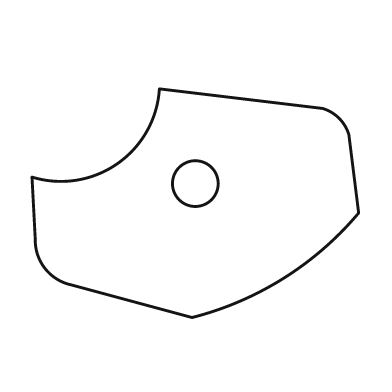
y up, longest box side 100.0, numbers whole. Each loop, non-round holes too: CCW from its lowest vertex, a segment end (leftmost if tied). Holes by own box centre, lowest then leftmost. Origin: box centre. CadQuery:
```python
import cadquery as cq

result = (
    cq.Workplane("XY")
    .moveTo(-1.0, -35.0)
    .threePointArc((27.0, -23.0), (50.0, -3.0))
    .lineTo(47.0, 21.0)
    .threePointArc((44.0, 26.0), (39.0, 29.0))
    .lineTo(-11.0, 35.0)
    .threePointArc((-24.0, 12.0), (-50.0, 8.0))
    .lineTo(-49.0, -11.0)
    .threePointArc((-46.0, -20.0), (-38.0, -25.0))
    .close()
    .moveTo(0.0, 6.0)
    .circle(7.0)
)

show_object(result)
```